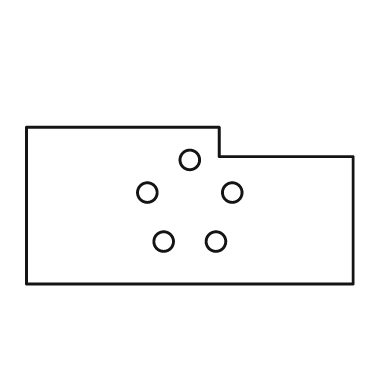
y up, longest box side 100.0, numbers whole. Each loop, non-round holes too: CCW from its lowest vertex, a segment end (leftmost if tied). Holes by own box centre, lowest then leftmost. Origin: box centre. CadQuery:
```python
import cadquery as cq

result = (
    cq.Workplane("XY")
    .moveTo(-50.0, -24.0)
    .lineTo(50.0, -24.0)
    .lineTo(50.0, 15.0)
    .lineTo(9.0, 15.0)
    .lineTo(9.0, 24.0)
    .lineTo(-50.0, 24.0)
    .close()
    .moveTo(-8.0, -11.0)
    .circle(3.0)
    .moveTo(8.0, -11.0)
    .circle(3.0)
    .moveTo(-13.0, 4.0)
    .circle(3.0)
    .moveTo(13.0, 4.0)
    .circle(3.0)
    .moveTo(0.0, 14.0)
    .circle(3.0)
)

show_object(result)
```